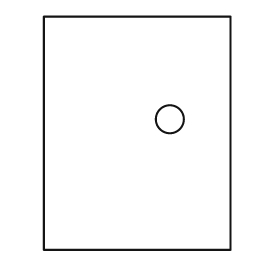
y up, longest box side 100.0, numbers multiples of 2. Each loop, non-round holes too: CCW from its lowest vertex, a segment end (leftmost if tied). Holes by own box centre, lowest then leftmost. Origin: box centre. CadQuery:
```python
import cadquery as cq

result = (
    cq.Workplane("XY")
    .moveTo(-40.0, -50.0)
    .lineTo(40.0, -50.0)
    .lineTo(40.0, 50.0)
    .lineTo(-40.0, 50.0)
    .close()
    .moveTo(14.0, 6.0)
    .circle(6.0)
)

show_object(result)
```